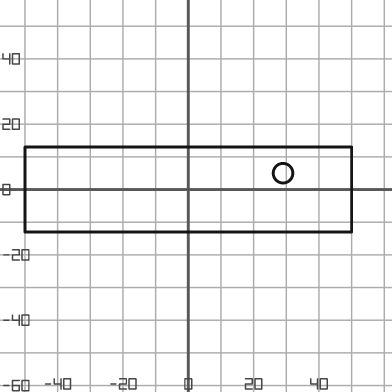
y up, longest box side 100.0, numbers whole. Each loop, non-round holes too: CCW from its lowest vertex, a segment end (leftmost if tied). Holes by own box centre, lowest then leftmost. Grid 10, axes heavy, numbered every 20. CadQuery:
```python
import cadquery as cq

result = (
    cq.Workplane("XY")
    .moveTo(-50.0, -13.0)
    .lineTo(50.0, -13.0)
    .lineTo(50.0, 13.0)
    .lineTo(-50.0, 13.0)
    .close()
    .moveTo(29.0, 5.0)
    .circle(3.0)
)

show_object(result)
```